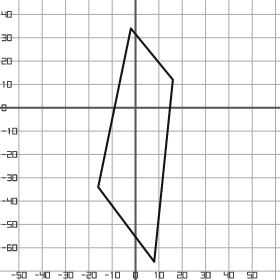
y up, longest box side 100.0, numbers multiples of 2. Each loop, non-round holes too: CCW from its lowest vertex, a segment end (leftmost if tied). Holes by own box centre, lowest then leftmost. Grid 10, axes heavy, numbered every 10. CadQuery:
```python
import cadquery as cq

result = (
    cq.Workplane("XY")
    .moveTo(8.0, -66.0)
    .lineTo(16.0, 12.0)
    .lineTo(-2.0, 34.0)
    .lineTo(-16.0, -34.0)
    .close()
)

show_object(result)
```